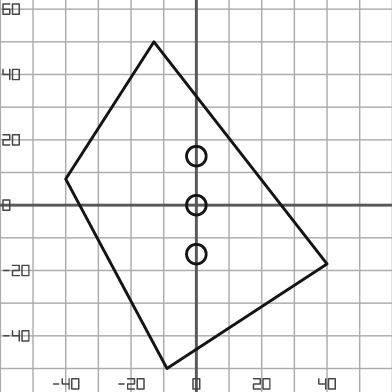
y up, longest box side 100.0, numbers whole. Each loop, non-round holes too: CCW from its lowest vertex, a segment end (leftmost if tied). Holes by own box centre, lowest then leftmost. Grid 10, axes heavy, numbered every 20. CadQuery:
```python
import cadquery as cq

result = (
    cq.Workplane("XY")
    .moveTo(-9.0, -50.0)
    .lineTo(40.0, -18.0)
    .lineTo(-13.0, 50.0)
    .lineTo(-40.0, 8.0)
    .close()
    .moveTo(0.0, -15.0)
    .circle(3.0)
    .moveTo(0.0, 0.0)
    .circle(3.0)
    .moveTo(0.0, 15.0)
    .circle(3.0)
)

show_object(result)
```